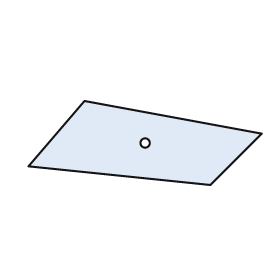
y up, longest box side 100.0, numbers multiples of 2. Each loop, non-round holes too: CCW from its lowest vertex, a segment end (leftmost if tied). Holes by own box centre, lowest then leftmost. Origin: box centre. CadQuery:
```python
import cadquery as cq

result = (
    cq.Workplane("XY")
    .moveTo(28.0, -18.0)
    .lineTo(50.0, 4.0)
    .lineTo(-26.0, 18.0)
    .lineTo(-50.0, -10.0)
    .close()
    .moveTo(0.0, 0.0)
    .circle(2.0)
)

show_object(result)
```